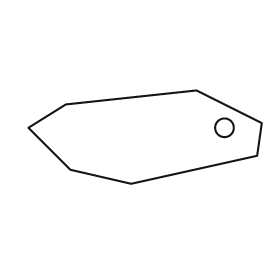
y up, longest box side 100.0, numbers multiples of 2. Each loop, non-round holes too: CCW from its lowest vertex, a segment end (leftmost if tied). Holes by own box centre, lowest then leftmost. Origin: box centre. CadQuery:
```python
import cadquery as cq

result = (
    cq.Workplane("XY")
    .moveTo(-6.0, -20.0)
    .lineTo(48.0, -8.0)
    .lineTo(50.0, 6.0)
    .lineTo(22.0, 20.0)
    .lineTo(-34.0, 14.0)
    .lineTo(-50.0, 4.0)
    .lineTo(-32.0, -14.0)
    .close()
    .moveTo(34.0, 4.0)
    .circle(4.0)
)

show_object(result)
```